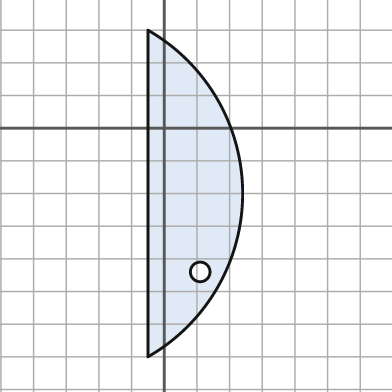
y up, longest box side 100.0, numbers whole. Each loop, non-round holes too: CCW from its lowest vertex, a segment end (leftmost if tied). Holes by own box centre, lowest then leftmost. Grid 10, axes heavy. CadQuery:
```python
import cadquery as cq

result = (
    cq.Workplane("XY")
    .moveTo(-5.0, -70.0)
    .threePointArc((24.0, -20.0), (-5.0, 30.0))
    .close()
    .moveTo(11.0, -44.0)
    .circle(3.0)
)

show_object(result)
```